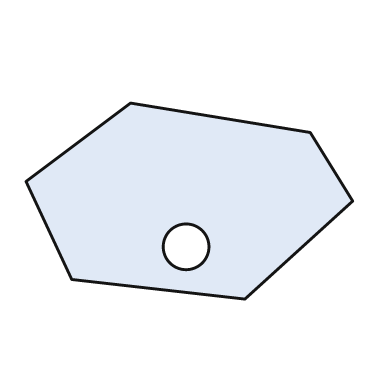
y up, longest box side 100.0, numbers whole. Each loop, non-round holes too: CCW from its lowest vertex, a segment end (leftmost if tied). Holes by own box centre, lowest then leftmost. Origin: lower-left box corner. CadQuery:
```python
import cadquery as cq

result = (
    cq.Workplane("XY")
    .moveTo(67.0, 0.0)
    .lineTo(100.0, 30.0)
    .lineTo(87.0, 51.0)
    .lineTo(32.0, 60.0)
    .lineTo(0.0, 36.0)
    .lineTo(14.0, 6.0)
    .close()
    .moveTo(49.0, 16.0)
    .circle(7.0)
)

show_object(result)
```